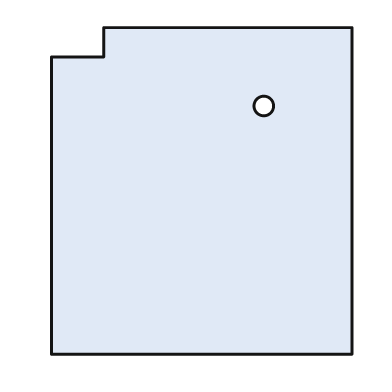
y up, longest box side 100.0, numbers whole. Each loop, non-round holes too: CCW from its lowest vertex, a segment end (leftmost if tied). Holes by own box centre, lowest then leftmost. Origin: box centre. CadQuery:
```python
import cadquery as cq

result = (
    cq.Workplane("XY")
    .moveTo(-46.0, -50.0)
    .lineTo(46.0, -50.0)
    .lineTo(46.0, 50.0)
    .lineTo(-30.0, 50.0)
    .lineTo(-30.0, 41.0)
    .lineTo(-46.0, 41.0)
    .close()
    .moveTo(19.0, 26.0)
    .circle(3.0)
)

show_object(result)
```